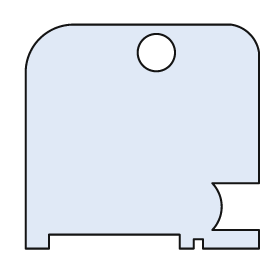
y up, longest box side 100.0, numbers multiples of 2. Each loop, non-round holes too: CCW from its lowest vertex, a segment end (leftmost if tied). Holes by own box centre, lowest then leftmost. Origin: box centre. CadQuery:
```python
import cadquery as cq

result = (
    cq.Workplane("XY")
    .moveTo(-50.0, -48.0)
    .lineTo(-40.0, -48.0)
    .lineTo(-40.0, -42.0)
    .lineTo(16.0, -42.0)
    .lineTo(16.0, -48.0)
    .lineTo(22.0, -48.0)
    .lineTo(22.0, -44.0)
    .lineTo(26.0, -44.0)
    .lineTo(26.0, -48.0)
    .lineTo(50.0, -48.0)
    .lineTo(50.0, -40.0)
    .lineTo(30.0, -40.0)
    .threePointArc((34.0, -30.0), (30.0, -20.0))
    .lineTo(50.0, -20.0)
    .lineTo(50.0, 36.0)
    .threePointArc((46.0, 44.0), (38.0, 48.0))
    .lineTo(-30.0, 48.0)
    .threePointArc((-44.0, 42.0), (-50.0, 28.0))
    .close()
    .moveTo(6.0, 36.0)
    .circle(8.0)
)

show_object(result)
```